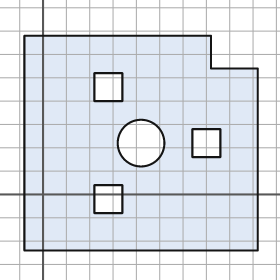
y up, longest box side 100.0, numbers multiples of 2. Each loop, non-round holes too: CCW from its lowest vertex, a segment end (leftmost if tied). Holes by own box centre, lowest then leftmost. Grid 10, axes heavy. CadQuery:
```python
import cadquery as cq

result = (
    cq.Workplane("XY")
    .moveTo(-8.0, -24.0)
    .lineTo(92.0, -24.0)
    .lineTo(92.0, 54.0)
    .lineTo(72.0, 54.0)
    .lineTo(72.0, 68.0)
    .lineTo(-8.0, 68.0)
    .close()
    .moveTo(22.0, -8.0)
    .lineTo(34.0, -8.0)
    .lineTo(34.0, 4.0)
    .lineTo(22.0, 4.0)
    .close()
    .moveTo(42.0, 22.0)
    .circle(10.0)
    .moveTo(64.0, 16.0)
    .lineTo(76.0, 16.0)
    .lineTo(76.0, 28.0)
    .lineTo(64.0, 28.0)
    .close()
    .moveTo(22.0, 40.0)
    .lineTo(34.0, 40.0)
    .lineTo(34.0, 52.0)
    .lineTo(22.0, 52.0)
    .close()
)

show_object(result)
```